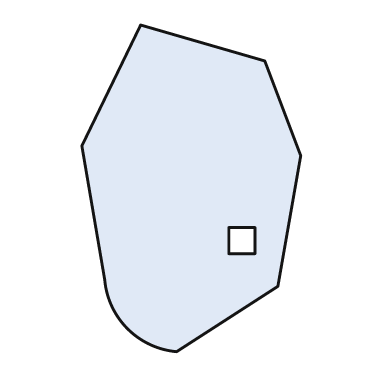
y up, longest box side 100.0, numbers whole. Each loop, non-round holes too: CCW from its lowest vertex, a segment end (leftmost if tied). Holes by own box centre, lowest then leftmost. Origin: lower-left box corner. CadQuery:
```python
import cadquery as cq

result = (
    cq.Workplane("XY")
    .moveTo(29.0, 0.0)
    .lineTo(60.0, 20.0)
    .lineTo(67.0, 60.0)
    .lineTo(56.0, 89.0)
    .lineTo(18.0, 100.0)
    .lineTo(0.0, 63.0)
    .lineTo(7.0, 22.0)
    .threePointArc((14.0, 7.0), (29.0, 0.0))
    .close()
    .moveTo(45.0, 30.0)
    .lineTo(53.0, 30.0)
    .lineTo(53.0, 38.0)
    .lineTo(45.0, 38.0)
    .close()
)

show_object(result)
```